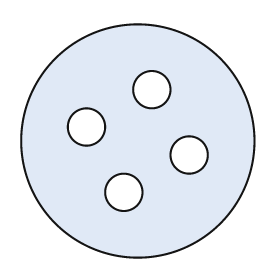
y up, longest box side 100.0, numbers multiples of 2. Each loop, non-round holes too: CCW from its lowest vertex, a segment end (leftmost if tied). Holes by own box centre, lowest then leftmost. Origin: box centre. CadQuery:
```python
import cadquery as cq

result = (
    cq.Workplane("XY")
    .moveTo(0.0, 0.0)
    .circle(50.0)
    .moveTo(-6.0, -22.0)
    .circle(8.0)
    .moveTo(22.0, -6.0)
    .circle(8.0)
    .moveTo(-22.0, 6.0)
    .circle(8.0)
    .moveTo(6.0, 22.0)
    .circle(8.0)
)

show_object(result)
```